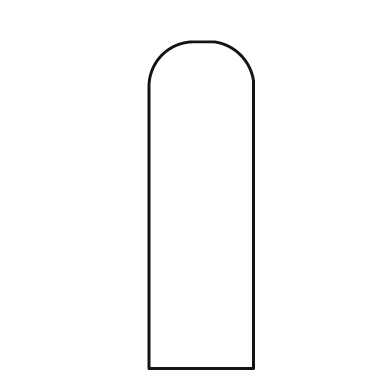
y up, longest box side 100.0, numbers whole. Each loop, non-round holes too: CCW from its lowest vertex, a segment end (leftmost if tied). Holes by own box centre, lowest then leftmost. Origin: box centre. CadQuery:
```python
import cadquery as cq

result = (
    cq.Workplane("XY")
    .moveTo(-16.0, -50.0)
    .lineTo(16.0, -50.0)
    .lineTo(16.0, 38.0)
    .threePointArc((12.0, 46.0), (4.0, 50.0))
    .lineTo(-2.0, 50.0)
    .threePointArc((-12.0, 46.0), (-16.0, 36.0))
    .close()
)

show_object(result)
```